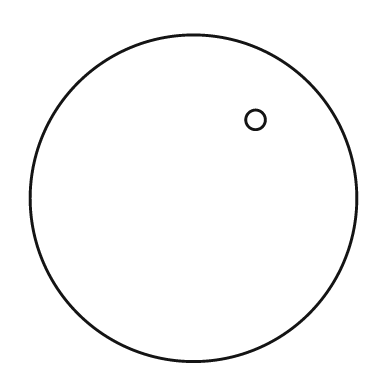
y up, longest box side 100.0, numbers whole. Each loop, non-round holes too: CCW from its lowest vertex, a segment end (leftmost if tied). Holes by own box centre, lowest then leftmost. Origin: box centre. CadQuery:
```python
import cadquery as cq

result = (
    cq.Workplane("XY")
    .moveTo(0.0, 0.0)
    .circle(50.0)
    .moveTo(19.0, 24.0)
    .circle(3.0)
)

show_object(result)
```